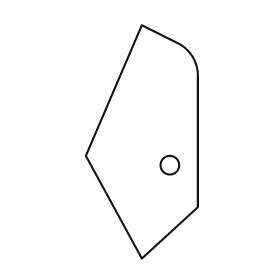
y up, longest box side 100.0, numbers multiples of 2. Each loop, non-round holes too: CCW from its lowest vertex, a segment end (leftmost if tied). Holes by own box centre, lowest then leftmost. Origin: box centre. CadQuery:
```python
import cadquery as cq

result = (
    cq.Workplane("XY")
    .moveTo(0.0, -50.0)
    .lineTo(24.0, -28.0)
    .lineTo(24.0, 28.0)
    .threePointArc((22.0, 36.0), (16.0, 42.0))
    .lineTo(0.0, 50.0)
    .lineTo(-24.0, -6.0)
    .close()
    .moveTo(12.0, -10.0)
    .circle(4.0)
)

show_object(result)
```